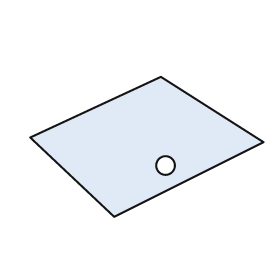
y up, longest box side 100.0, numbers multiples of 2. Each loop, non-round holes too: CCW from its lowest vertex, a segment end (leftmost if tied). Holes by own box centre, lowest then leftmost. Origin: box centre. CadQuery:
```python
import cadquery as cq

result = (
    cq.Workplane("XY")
    .moveTo(-14.0, -30.0)
    .lineTo(50.0, 2.0)
    .lineTo(6.0, 30.0)
    .lineTo(-50.0, 4.0)
    .close()
    .moveTo(8.0, -8.0)
    .circle(4.0)
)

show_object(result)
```